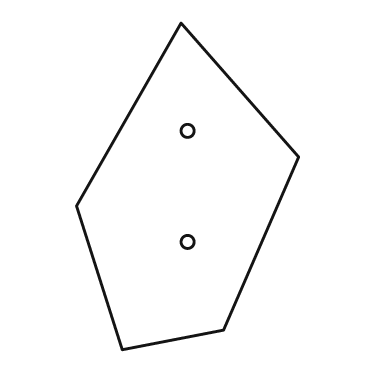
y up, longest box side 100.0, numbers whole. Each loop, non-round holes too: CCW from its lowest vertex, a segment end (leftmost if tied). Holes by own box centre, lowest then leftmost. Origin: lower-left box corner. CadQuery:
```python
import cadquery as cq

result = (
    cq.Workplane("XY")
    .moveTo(14.0, 0.0)
    .lineTo(45.0, 6.0)
    .lineTo(68.0, 59.0)
    .lineTo(32.0, 100.0)
    .lineTo(0.0, 44.0)
    .close()
    .moveTo(34.0, 33.0)
    .circle(2.0)
    .moveTo(34.0, 67.0)
    .circle(2.0)
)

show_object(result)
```